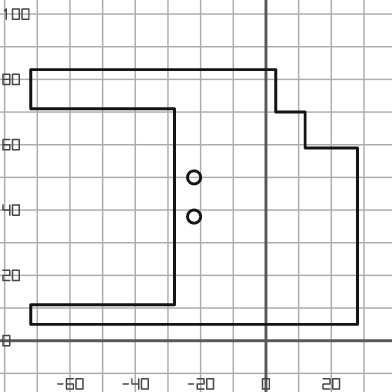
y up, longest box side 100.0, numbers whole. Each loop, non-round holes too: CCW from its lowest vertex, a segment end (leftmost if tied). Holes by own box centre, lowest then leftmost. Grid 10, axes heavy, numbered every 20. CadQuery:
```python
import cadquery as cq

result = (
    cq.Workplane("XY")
    .moveTo(-72.0, 5.0)
    .lineTo(28.0, 5.0)
    .lineTo(28.0, 59.0)
    .lineTo(12.0, 59.0)
    .lineTo(12.0, 70.0)
    .lineTo(3.0, 70.0)
    .lineTo(3.0, 83.0)
    .lineTo(-72.0, 83.0)
    .lineTo(-72.0, 71.0)
    .lineTo(-28.0, 71.0)
    .lineTo(-28.0, 11.0)
    .lineTo(-72.0, 11.0)
    .close()
    .moveTo(-22.0, 38.0)
    .circle(2.0)
    .moveTo(-22.0, 50.0)
    .circle(2.0)
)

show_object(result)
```